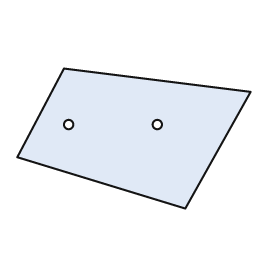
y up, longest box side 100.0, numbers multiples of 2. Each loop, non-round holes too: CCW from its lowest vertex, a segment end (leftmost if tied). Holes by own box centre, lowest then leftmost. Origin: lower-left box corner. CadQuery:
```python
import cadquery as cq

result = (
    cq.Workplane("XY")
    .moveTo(72.0, 0.0)
    .lineTo(100.0, 50.0)
    .lineTo(20.0, 60.0)
    .lineTo(0.0, 22.0)
    .close()
    .moveTo(22.0, 36.0)
    .circle(2.0)
    .moveTo(60.0, 36.0)
    .circle(2.0)
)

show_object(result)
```